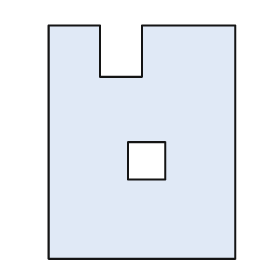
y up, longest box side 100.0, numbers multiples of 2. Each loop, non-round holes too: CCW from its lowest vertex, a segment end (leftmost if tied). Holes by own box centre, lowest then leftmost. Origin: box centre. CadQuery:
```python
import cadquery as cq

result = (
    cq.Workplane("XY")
    .moveTo(-40.0, -50.0)
    .lineTo(40.0, -50.0)
    .lineTo(40.0, 50.0)
    .lineTo(0.0, 50.0)
    .lineTo(0.0, 28.0)
    .lineTo(-18.0, 28.0)
    .lineTo(-18.0, 50.0)
    .lineTo(-40.0, 50.0)
    .close()
    .moveTo(-6.0, -16.0)
    .lineTo(10.0, -16.0)
    .lineTo(10.0, 0.0)
    .lineTo(-6.0, 0.0)
    .close()
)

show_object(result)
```